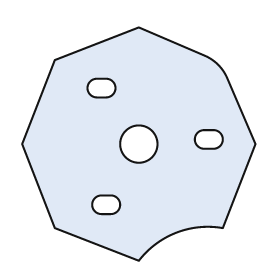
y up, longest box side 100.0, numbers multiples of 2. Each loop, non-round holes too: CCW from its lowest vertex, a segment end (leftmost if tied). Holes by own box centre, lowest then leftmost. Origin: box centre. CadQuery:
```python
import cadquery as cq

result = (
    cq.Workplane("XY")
    .moveTo(0.0, -50.0)
    .threePointArc((16.0, -38.0), (36.0, -36.0))
    .lineTo(50.0, 0.0)
    .lineTo(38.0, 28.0)
    .threePointArc((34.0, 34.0), (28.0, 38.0))
    .lineTo(0.0, 50.0)
    .lineTo(-36.0, 36.0)
    .lineTo(-50.0, 0.0)
    .lineTo(-36.0, -36.0)
    .close()
    .moveTo(-16.0, -30.0)
    .lineTo(-12.0, -30.0)
    .threePointArc((-8.0, -26.0), (-12.0, -22.0))
    .lineTo(-16.0, -22.0)
    .threePointArc((-20.0, -26.0), (-16.0, -30.0))
    .close()
    .moveTo(0.0, 0.0)
    .circle(8.0)
    .moveTo(28.0, -2.0)
    .lineTo(32.0, -2.0)
    .threePointArc((36.0, 2.0), (32.0, 6.0))
    .lineTo(28.0, 6.0)
    .threePointArc((24.0, 2.0), (28.0, -2.0))
    .close()
    .moveTo(-18.0, 20.0)
    .lineTo(-14.0, 20.0)
    .threePointArc((-10.0, 24.0), (-14.0, 28.0))
    .lineTo(-18.0, 28.0)
    .threePointArc((-22.0, 24.0), (-18.0, 20.0))
    .close()
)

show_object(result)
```